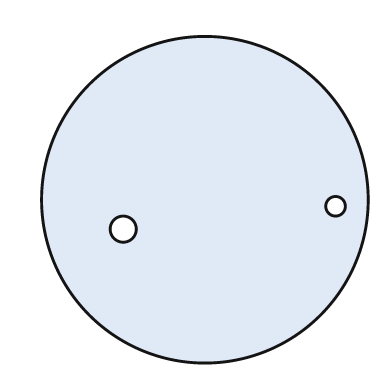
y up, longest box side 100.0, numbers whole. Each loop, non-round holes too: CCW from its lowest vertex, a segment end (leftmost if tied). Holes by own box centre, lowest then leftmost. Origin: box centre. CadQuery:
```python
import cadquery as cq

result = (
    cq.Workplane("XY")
    .moveTo(0.0, 0.0)
    .circle(50.0)
    .moveTo(-25.0, -9.0)
    .circle(4.0)
    .moveTo(40.0, -2.0)
    .circle(3.0)
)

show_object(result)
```